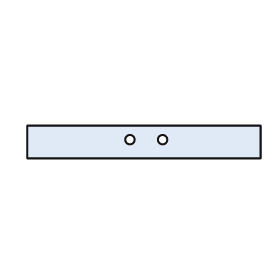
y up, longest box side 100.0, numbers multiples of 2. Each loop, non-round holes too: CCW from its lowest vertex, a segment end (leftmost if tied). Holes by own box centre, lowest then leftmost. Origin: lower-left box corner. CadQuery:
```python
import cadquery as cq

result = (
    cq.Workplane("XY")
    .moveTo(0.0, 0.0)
    .lineTo(100.0, 0.0)
    .lineTo(100.0, 14.0)
    .lineTo(0.0, 14.0)
    .close()
    .moveTo(44.0, 8.0)
    .circle(2.0)
    .moveTo(58.0, 8.0)
    .circle(2.0)
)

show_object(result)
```